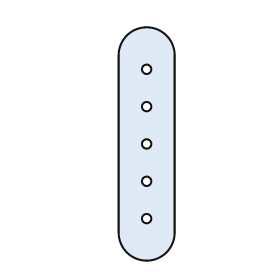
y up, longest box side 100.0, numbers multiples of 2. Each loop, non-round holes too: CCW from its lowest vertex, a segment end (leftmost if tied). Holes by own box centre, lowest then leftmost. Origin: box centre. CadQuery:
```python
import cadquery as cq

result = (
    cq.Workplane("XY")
    .moveTo(-12.0, -38.0)
    .threePointArc((0.0, -50.0), (12.0, -38.0))
    .lineTo(12.0, 38.0)
    .threePointArc((0.0, 50.0), (-12.0, 38.0))
    .close()
    .moveTo(0.0, -32.0)
    .circle(2.0)
    .moveTo(0.0, -16.0)
    .circle(2.0)
    .moveTo(0.0, 0.0)
    .circle(2.0)
    .moveTo(0.0, 16.0)
    .circle(2.0)
    .moveTo(0.0, 32.0)
    .circle(2.0)
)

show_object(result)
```